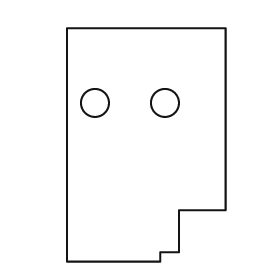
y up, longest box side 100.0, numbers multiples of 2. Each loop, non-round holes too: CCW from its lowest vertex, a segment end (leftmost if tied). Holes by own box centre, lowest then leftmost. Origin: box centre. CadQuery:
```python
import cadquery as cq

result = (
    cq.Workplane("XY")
    .moveTo(-34.0, -50.0)
    .lineTo(6.0, -50.0)
    .lineTo(6.0, -46.0)
    .lineTo(14.0, -46.0)
    .lineTo(14.0, -28.0)
    .lineTo(34.0, -28.0)
    .lineTo(34.0, 50.0)
    .lineTo(-34.0, 50.0)
    .close()
    .moveTo(-22.0, 18.0)
    .circle(6.0)
    .moveTo(8.0, 18.0)
    .circle(6.0)
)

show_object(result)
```